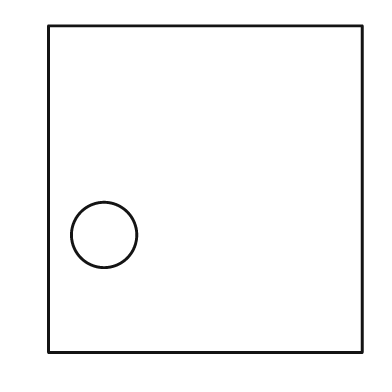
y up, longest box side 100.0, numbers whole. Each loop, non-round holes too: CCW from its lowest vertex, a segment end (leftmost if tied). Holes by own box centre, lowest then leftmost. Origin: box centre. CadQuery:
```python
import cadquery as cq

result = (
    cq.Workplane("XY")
    .moveTo(-48.0, -50.0)
    .lineTo(48.0, -50.0)
    .lineTo(48.0, 50.0)
    .lineTo(-48.0, 50.0)
    .close()
    .moveTo(-31.0, -14.0)
    .circle(10.0)
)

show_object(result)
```